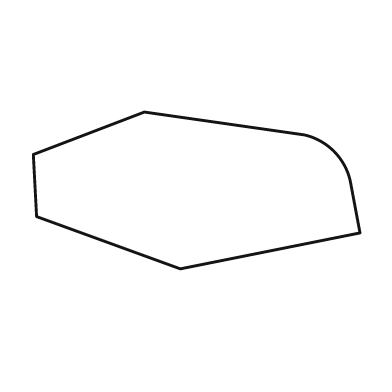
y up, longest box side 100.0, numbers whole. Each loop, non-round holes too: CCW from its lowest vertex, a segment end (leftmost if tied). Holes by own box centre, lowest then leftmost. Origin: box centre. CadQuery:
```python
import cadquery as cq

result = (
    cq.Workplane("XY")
    .moveTo(-5.0, -24.0)
    .lineTo(50.0, -13.0)
    .lineTo(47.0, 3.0)
    .threePointArc((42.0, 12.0), (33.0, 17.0))
    .lineTo(-16.0, 24.0)
    .lineTo(-50.0, 11.0)
    .lineTo(-49.0, -8.0)
    .close()
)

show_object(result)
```